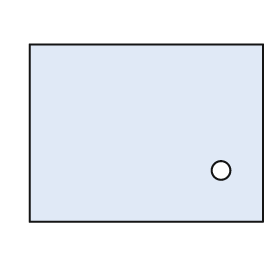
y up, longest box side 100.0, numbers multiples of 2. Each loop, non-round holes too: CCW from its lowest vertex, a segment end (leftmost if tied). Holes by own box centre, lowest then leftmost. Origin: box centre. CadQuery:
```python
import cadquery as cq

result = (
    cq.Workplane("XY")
    .moveTo(-50.0, -38.0)
    .lineTo(50.0, -38.0)
    .lineTo(50.0, 38.0)
    .lineTo(-50.0, 38.0)
    .close()
    .moveTo(32.0, -16.0)
    .circle(4.0)
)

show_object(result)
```